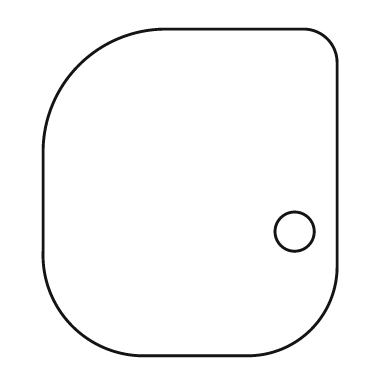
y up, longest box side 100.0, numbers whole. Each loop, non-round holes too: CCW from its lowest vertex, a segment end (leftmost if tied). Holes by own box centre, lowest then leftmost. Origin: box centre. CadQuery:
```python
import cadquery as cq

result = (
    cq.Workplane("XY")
    .moveTo(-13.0, -50.0)
    .lineTo(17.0, -50.0)
    .threePointArc((37.0, -42.0), (45.0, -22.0))
    .lineTo(45.0, 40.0)
    .threePointArc((42.0, 47.0), (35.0, 50.0))
    .lineTo(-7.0, 50.0)
    .threePointArc((-34.0, 39.0), (-45.0, 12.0))
    .lineTo(-45.0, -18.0)
    .threePointArc((-36.0, -41.0), (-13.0, -50.0))
    .close()
    .moveTo(32.0, -12.0)
    .circle(6.0)
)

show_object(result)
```